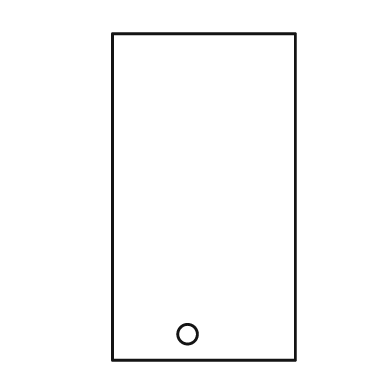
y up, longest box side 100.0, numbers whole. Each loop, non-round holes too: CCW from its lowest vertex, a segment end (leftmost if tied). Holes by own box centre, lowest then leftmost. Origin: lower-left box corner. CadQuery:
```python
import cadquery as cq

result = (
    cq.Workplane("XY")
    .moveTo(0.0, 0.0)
    .lineTo(56.0, 0.0)
    .lineTo(56.0, 100.0)
    .lineTo(0.0, 100.0)
    .close()
    .moveTo(23.0, 8.0)
    .circle(3.0)
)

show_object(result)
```